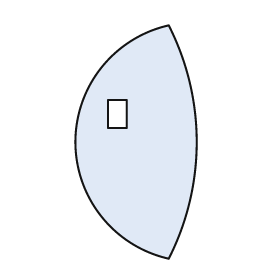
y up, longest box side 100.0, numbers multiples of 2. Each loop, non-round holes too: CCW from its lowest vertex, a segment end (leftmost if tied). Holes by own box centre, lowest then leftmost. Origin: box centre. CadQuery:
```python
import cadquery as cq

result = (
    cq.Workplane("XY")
    .moveTo(14.0, -50.0)
    .threePointArc((26.0, 0.0), (14.0, 50.0))
    .threePointArc((-26.0, 0.0), (14.0, -50.0))
    .close()
    .moveTo(-12.0, 6.0)
    .lineTo(-4.0, 6.0)
    .lineTo(-4.0, 18.0)
    .lineTo(-12.0, 18.0)
    .close()
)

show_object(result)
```